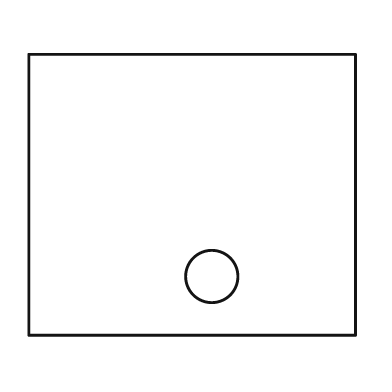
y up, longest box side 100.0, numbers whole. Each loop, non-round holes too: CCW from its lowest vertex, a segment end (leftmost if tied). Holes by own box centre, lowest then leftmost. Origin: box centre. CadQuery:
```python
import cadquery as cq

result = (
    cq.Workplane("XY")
    .moveTo(-50.0, -43.0)
    .lineTo(50.0, -43.0)
    .lineTo(50.0, 43.0)
    .lineTo(-50.0, 43.0)
    .close()
    .moveTo(6.0, -25.0)
    .circle(8.0)
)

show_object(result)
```